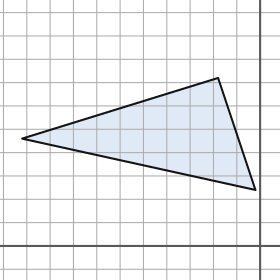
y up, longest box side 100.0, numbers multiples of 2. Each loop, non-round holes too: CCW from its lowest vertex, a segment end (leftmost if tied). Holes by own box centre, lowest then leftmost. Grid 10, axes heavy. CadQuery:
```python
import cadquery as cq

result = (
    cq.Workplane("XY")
    .moveTo(-2.0, 24.0)
    .lineTo(-18.0, 72.0)
    .lineTo(-102.0, 46.0)
    .close()
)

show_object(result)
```